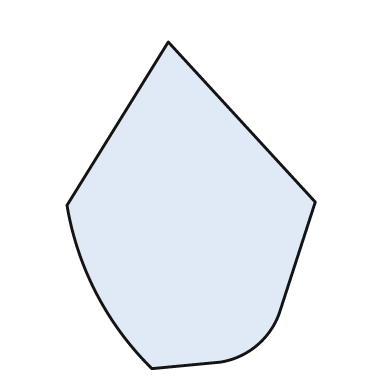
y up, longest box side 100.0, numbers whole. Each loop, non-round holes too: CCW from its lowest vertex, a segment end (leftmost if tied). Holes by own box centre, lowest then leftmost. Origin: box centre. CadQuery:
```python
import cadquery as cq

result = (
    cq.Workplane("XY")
    .moveTo(-12.0, -50.0)
    .lineTo(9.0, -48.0)
    .threePointArc((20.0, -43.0), (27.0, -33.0))
    .lineTo(38.0, 1.0)
    .lineTo(-7.0, 50.0)
    .lineTo(-38.0, 0.0)
    .threePointArc((-29.0, -27.0), (-12.0, -50.0))
    .close()
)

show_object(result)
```